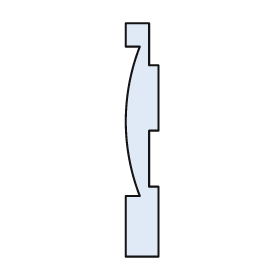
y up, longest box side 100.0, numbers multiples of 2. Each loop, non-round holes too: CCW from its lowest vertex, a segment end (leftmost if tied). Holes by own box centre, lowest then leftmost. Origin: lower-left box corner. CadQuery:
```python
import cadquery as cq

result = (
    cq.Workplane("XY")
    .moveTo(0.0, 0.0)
    .lineTo(14.0, 0.0)
    .lineTo(14.0, 30.0)
    .lineTo(10.0, 30.0)
    .lineTo(10.0, 54.0)
    .lineTo(14.0, 54.0)
    .lineTo(14.0, 82.0)
    .lineTo(10.0, 82.0)
    .lineTo(10.0, 100.0)
    .lineTo(0.0, 100.0)
    .lineTo(0.0, 90.0)
    .lineTo(6.0, 90.0)
    .threePointArc((0.0, 58.0), (6.0, 26.0))
    .lineTo(0.0, 26.0)
    .close()
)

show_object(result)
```